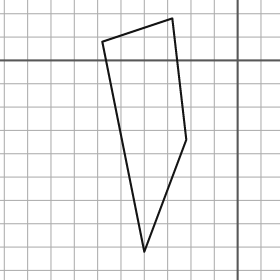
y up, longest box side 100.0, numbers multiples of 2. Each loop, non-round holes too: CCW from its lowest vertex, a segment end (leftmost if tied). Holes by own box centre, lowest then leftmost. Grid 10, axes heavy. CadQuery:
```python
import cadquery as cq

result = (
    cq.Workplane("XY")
    .moveTo(-40.0, -82.0)
    .lineTo(-22.0, -34.0)
    .lineTo(-28.0, 18.0)
    .lineTo(-58.0, 8.0)
    .close()
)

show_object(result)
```